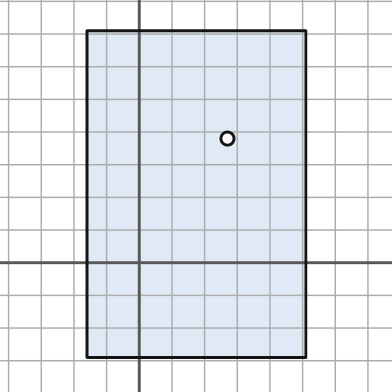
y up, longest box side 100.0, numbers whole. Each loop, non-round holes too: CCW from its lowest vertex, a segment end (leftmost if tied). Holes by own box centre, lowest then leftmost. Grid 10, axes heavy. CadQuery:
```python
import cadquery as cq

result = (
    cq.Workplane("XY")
    .moveTo(-16.0, -29.0)
    .lineTo(51.0, -29.0)
    .lineTo(51.0, 71.0)
    .lineTo(-16.0, 71.0)
    .close()
    .moveTo(27.0, 38.0)
    .circle(2.0)
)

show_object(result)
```